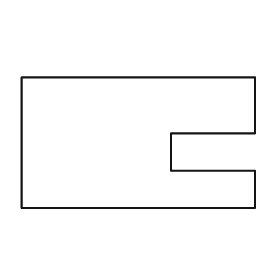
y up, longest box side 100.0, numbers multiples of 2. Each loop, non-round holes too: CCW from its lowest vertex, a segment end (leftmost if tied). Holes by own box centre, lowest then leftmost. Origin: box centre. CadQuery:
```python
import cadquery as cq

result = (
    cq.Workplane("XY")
    .moveTo(-50.0, -28.0)
    .lineTo(50.0, -28.0)
    .lineTo(50.0, -12.0)
    .lineTo(14.0, -12.0)
    .lineTo(14.0, 4.0)
    .lineTo(50.0, 4.0)
    .lineTo(50.0, 28.0)
    .lineTo(-50.0, 28.0)
    .close()
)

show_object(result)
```